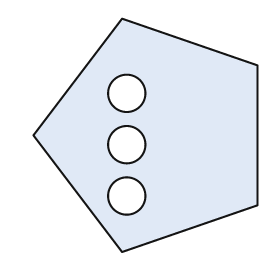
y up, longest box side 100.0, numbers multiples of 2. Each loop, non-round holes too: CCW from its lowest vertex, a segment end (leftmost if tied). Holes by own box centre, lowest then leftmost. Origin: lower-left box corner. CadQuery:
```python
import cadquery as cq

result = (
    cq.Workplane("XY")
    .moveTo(38.0, 0.0)
    .lineTo(96.0, 20.0)
    .lineTo(96.0, 80.0)
    .lineTo(38.0, 100.0)
    .lineTo(0.0, 50.0)
    .close()
    .moveTo(40.0, 24.0)
    .circle(8.0)
    .moveTo(40.0, 46.0)
    .circle(8.0)
    .moveTo(40.0, 68.0)
    .circle(8.0)
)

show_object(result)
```